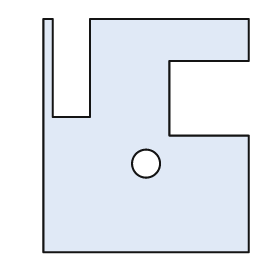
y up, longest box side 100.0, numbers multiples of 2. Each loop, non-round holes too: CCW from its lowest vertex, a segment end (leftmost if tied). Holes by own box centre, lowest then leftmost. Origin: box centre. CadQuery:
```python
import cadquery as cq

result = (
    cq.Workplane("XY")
    .moveTo(-44.0, -50.0)
    .lineTo(44.0, -50.0)
    .lineTo(44.0, 0.0)
    .lineTo(10.0, 0.0)
    .lineTo(10.0, 32.0)
    .lineTo(44.0, 32.0)
    .lineTo(44.0, 50.0)
    .lineTo(-24.0, 50.0)
    .lineTo(-24.0, 8.0)
    .lineTo(-40.0, 8.0)
    .lineTo(-40.0, 50.0)
    .lineTo(-44.0, 50.0)
    .close()
    .moveTo(0.0, -12.0)
    .circle(6.0)
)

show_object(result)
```